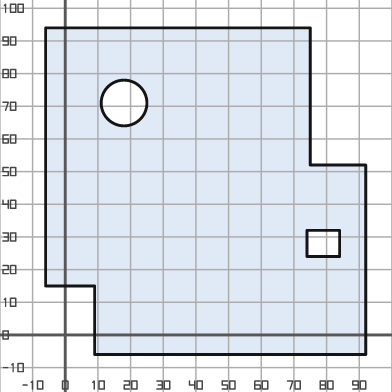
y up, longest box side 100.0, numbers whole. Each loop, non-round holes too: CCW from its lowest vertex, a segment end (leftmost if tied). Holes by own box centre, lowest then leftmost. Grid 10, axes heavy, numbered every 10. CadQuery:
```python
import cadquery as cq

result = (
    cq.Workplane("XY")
    .moveTo(9.0, -6.0)
    .lineTo(92.0, -6.0)
    .lineTo(92.0, 52.0)
    .lineTo(75.0, 52.0)
    .lineTo(75.0, 94.0)
    .lineTo(-6.0, 94.0)
    .lineTo(-6.0, 15.0)
    .lineTo(9.0, 15.0)
    .close()
    .moveTo(74.0, 24.0)
    .lineTo(84.0, 24.0)
    .lineTo(84.0, 32.0)
    .lineTo(74.0, 32.0)
    .close()
    .moveTo(18.0, 71.0)
    .circle(7.0)
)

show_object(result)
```